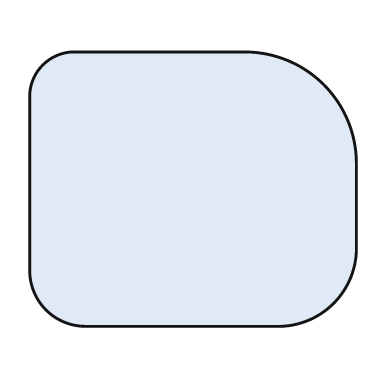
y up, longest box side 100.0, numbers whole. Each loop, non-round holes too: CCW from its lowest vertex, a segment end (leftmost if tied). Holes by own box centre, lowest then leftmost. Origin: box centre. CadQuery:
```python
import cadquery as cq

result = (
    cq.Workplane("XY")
    .moveTo(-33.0, -42.0)
    .lineTo(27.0, -42.0)
    .threePointArc((43.0, -35.0), (50.0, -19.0))
    .lineTo(50.0, 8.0)
    .threePointArc((40.0, 32.0), (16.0, 42.0))
    .lineTo(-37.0, 42.0)
    .threePointArc((-46.0, 38.0), (-50.0, 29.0))
    .lineTo(-50.0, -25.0)
    .threePointArc((-45.0, -37.0), (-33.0, -42.0))
    .close()
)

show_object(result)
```